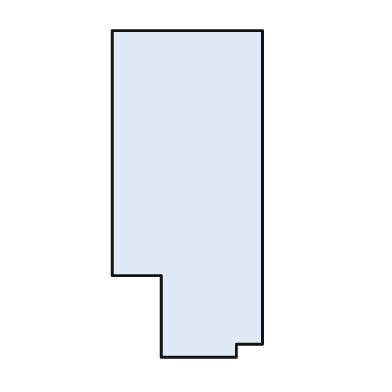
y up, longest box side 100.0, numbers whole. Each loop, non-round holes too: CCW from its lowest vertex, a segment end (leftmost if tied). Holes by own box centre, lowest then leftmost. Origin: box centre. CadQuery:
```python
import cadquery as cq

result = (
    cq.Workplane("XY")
    .moveTo(-8.0, -50.0)
    .lineTo(15.0, -50.0)
    .lineTo(15.0, -46.0)
    .lineTo(23.0, -46.0)
    .lineTo(23.0, 50.0)
    .lineTo(-23.0, 50.0)
    .lineTo(-23.0, -25.0)
    .lineTo(-8.0, -25.0)
    .close()
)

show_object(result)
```